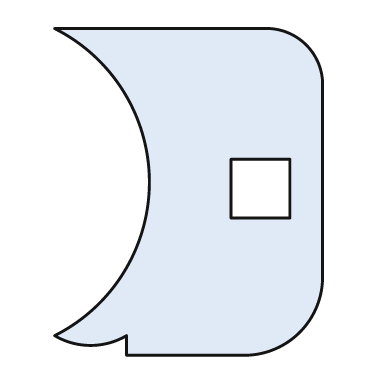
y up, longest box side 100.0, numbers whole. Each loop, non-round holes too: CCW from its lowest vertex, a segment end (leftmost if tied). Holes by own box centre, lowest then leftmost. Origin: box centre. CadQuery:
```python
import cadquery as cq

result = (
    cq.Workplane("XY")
    .moveTo(-19.0, -50.0)
    .lineTo(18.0, -50.0)
    .threePointArc((34.0, -43.0), (41.0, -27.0))
    .lineTo(41.0, 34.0)
    .threePointArc((36.0, 45.0), (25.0, 50.0))
    .lineTo(-41.0, 50.0)
    .threePointArc((-12.0, 3.0), (-41.0, -44.0))
    .threePointArc((-30.0, -47.0), (-19.0, -44.0))
    .close()
    .moveTo(13.0, -8.0)
    .lineTo(31.0, -8.0)
    .lineTo(31.0, 10.0)
    .lineTo(13.0, 10.0)
    .close()
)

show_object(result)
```